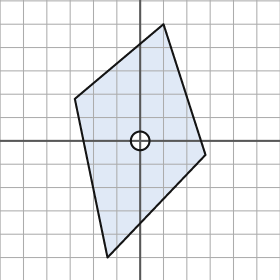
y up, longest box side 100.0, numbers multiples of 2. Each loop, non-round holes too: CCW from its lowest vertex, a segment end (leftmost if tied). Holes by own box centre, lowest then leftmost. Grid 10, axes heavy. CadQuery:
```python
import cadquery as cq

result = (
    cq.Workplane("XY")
    .moveTo(-14.0, -50.0)
    .lineTo(28.0, -6.0)
    .lineTo(10.0, 50.0)
    .lineTo(-28.0, 18.0)
    .close()
    .moveTo(0.0, 0.0)
    .circle(4.0)
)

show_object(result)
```